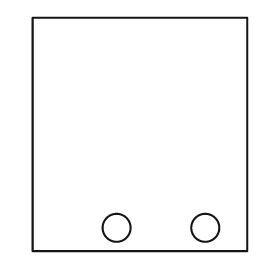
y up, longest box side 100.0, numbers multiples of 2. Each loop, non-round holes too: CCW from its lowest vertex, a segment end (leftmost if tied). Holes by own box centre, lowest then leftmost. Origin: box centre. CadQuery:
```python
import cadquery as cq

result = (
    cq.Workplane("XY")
    .moveTo(-46.0, -50.0)
    .lineTo(46.0, -50.0)
    .lineTo(46.0, 50.0)
    .lineTo(-46.0, 50.0)
    .close()
    .moveTo(-10.0, -40.0)
    .circle(6.0)
    .moveTo(28.0, -40.0)
    .circle(6.0)
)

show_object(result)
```